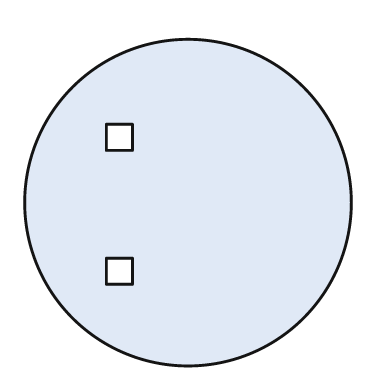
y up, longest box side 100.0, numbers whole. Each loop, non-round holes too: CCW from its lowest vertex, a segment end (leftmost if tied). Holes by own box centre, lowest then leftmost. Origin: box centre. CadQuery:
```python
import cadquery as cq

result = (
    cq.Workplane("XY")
    .moveTo(0.0, 0.0)
    .circle(50.0)
    .moveTo(-25.0, -25.0)
    .lineTo(-17.0, -25.0)
    .lineTo(-17.0, -17.0)
    .lineTo(-25.0, -17.0)
    .close()
    .moveTo(-25.0, 16.0)
    .lineTo(-17.0, 16.0)
    .lineTo(-17.0, 24.0)
    .lineTo(-25.0, 24.0)
    .close()
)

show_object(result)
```